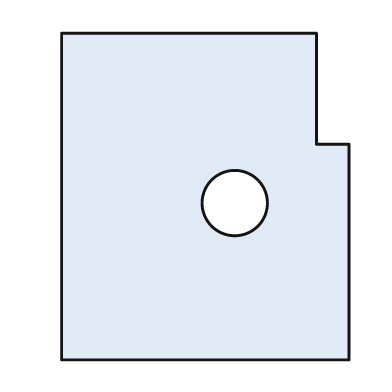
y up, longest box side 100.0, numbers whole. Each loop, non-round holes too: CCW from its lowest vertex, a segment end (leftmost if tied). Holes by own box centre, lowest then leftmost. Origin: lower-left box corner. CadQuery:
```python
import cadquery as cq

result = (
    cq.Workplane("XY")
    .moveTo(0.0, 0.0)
    .lineTo(88.0, 0.0)
    .lineTo(88.0, 66.0)
    .lineTo(78.0, 66.0)
    .lineTo(78.0, 100.0)
    .lineTo(0.0, 100.0)
    .close()
    .moveTo(53.0, 48.0)
    .circle(10.0)
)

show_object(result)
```